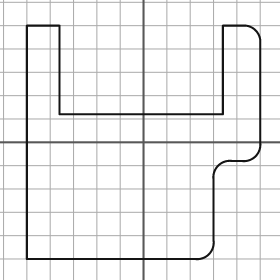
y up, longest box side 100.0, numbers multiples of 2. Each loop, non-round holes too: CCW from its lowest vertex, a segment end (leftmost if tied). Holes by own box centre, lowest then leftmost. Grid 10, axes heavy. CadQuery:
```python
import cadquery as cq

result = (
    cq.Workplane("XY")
    .moveTo(-50.0, -50.0)
    .lineTo(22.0, -50.0)
    .threePointArc((28.0, -48.0), (30.0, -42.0))
    .lineTo(30.0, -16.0)
    .threePointArc((32.0, -10.0), (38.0, -8.0))
    .lineTo(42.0, -8.0)
    .threePointArc((48.0, -6.0), (50.0, 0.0))
    .lineTo(50.0, 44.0)
    .threePointArc((48.0, 48.0), (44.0, 50.0))
    .lineTo(34.0, 50.0)
    .lineTo(34.0, 12.0)
    .lineTo(-36.0, 12.0)
    .lineTo(-36.0, 50.0)
    .lineTo(-50.0, 50.0)
    .close()
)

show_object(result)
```